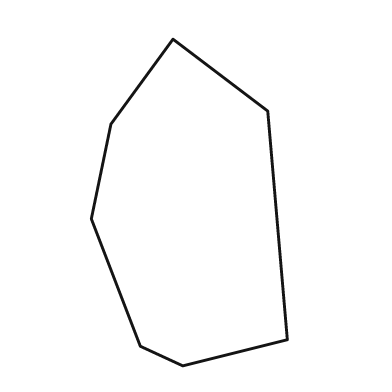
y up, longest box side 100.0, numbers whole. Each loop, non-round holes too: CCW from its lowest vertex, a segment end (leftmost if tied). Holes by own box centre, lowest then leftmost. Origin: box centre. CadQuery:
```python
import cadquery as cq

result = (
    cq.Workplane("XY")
    .moveTo(-2.0, -50.0)
    .lineTo(30.0, -42.0)
    .lineTo(24.0, 28.0)
    .lineTo(-5.0, 50.0)
    .lineTo(-24.0, 24.0)
    .lineTo(-30.0, -5.0)
    .lineTo(-15.0, -44.0)
    .close()
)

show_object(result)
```